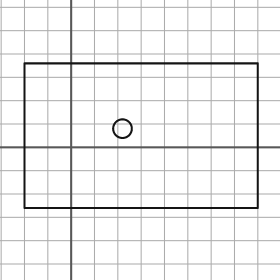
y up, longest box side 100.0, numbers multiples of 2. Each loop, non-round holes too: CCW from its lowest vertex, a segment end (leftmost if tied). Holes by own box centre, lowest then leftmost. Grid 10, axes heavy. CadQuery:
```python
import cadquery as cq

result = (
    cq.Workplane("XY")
    .moveTo(-20.0, -26.0)
    .lineTo(80.0, -26.0)
    .lineTo(80.0, 36.0)
    .lineTo(-20.0, 36.0)
    .close()
    .moveTo(22.0, 8.0)
    .circle(4.0)
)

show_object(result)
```